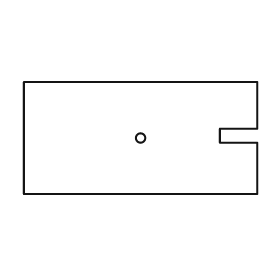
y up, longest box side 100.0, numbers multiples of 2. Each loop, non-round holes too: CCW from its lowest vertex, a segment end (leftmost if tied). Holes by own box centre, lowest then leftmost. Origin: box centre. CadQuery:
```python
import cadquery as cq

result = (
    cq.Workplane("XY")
    .moveTo(-50.0, -24.0)
    .lineTo(50.0, -24.0)
    .lineTo(50.0, -2.0)
    .lineTo(34.0, -2.0)
    .lineTo(34.0, 4.0)
    .lineTo(50.0, 4.0)
    .lineTo(50.0, 24.0)
    .lineTo(-50.0, 24.0)
    .close()
    .moveTo(0.0, 0.0)
    .circle(2.0)
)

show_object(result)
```